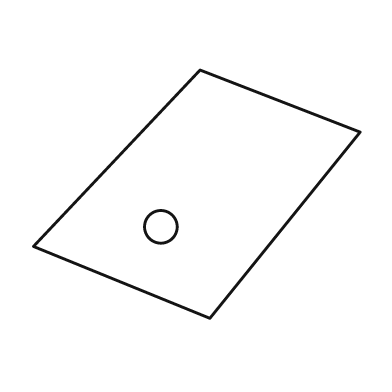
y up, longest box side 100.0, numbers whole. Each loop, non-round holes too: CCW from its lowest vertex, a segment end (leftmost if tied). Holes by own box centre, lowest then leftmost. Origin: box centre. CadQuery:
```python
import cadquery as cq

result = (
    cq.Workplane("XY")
    .moveTo(4.0, -38.0)
    .lineTo(50.0, 19.0)
    .lineTo(1.0, 38.0)
    .lineTo(-50.0, -16.0)
    .close()
    .moveTo(-11.0, -10.0)
    .circle(5.0)
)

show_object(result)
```